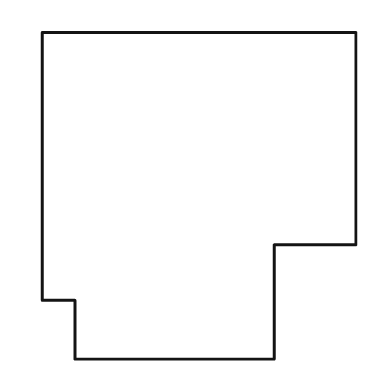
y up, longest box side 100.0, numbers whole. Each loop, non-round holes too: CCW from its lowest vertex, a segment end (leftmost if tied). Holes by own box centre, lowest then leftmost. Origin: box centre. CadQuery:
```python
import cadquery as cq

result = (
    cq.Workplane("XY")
    .moveTo(-38.0, -50.0)
    .lineTo(23.0, -50.0)
    .lineTo(23.0, -15.0)
    .lineTo(48.0, -15.0)
    .lineTo(48.0, 50.0)
    .lineTo(-48.0, 50.0)
    .lineTo(-48.0, -32.0)
    .lineTo(-38.0, -32.0)
    .close()
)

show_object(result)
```